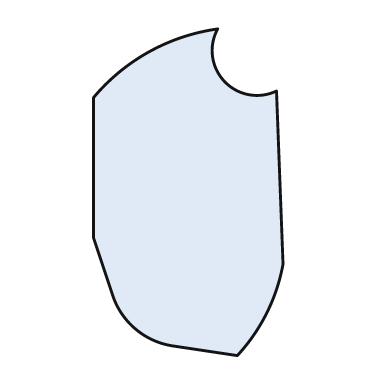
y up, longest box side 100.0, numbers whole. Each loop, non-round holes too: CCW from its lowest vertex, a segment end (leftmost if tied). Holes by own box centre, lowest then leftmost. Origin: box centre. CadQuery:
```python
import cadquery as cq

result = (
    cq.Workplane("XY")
    .moveTo(15.0, -50.0)
    .threePointArc((24.0, -37.0), (29.0, -22.0))
    .lineTo(27.0, 31.0)
    .threePointArc((11.0, 34.0), (9.0, 50.0))
    .threePointArc((-12.0, 43.0), (-29.0, 29.0))
    .lineTo(-29.0, -14.0)
    .lineTo(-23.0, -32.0)
    .threePointArc((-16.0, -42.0), (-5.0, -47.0))
    .close()
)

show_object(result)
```